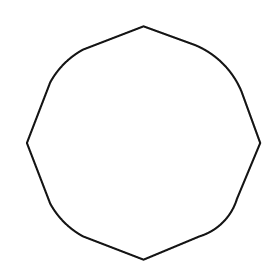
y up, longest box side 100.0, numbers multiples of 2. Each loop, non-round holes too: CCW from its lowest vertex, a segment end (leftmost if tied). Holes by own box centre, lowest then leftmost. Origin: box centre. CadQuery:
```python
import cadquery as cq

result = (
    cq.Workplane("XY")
    .moveTo(0.0, -50.0)
    .lineTo(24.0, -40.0)
    .threePointArc((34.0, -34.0), (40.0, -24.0))
    .lineTo(50.0, 0.0)
    .lineTo(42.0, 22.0)
    .threePointArc((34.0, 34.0), (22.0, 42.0))
    .lineTo(0.0, 50.0)
    .lineTo(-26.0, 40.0)
    .threePointArc((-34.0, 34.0), (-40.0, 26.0))
    .lineTo(-50.0, 0.0)
    .lineTo(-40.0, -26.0)
    .threePointArc((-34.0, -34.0), (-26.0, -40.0))
    .close()
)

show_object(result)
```